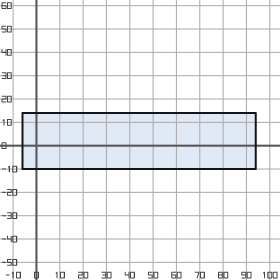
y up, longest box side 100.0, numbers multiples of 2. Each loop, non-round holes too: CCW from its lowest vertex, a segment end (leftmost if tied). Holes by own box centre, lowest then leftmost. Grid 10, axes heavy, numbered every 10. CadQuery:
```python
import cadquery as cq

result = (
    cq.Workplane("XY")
    .moveTo(-6.0, -10.0)
    .lineTo(94.0, -10.0)
    .lineTo(94.0, 14.0)
    .lineTo(-6.0, 14.0)
    .close()
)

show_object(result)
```